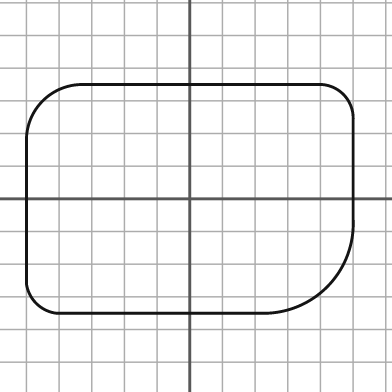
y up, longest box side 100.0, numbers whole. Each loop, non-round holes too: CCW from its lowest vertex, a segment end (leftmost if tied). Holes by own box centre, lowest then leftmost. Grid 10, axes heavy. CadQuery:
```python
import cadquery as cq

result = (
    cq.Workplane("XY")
    .moveTo(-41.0, -35.0)
    .lineTo(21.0, -35.0)
    .threePointArc((42.0, -27.0), (50.0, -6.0))
    .lineTo(50.0, 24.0)
    .threePointArc((47.0, 32.0), (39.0, 35.0))
    .lineTo(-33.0, 35.0)
    .threePointArc((-45.0, 30.0), (-50.0, 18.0))
    .lineTo(-50.0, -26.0)
    .threePointArc((-47.0, -32.0), (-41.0, -35.0))
    .close()
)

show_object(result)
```